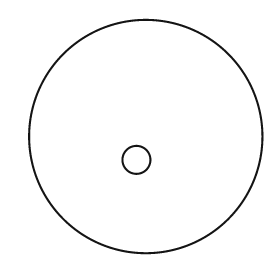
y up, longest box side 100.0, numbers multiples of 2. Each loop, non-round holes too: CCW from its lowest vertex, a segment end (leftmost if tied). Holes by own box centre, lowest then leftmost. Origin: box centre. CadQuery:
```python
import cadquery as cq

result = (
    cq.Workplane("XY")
    .moveTo(0.0, 0.0)
    .circle(50.0)
    .moveTo(-4.0, -10.0)
    .circle(6.0)
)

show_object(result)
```